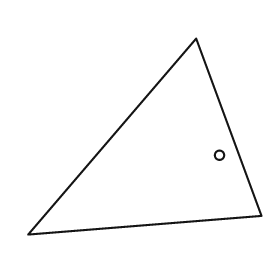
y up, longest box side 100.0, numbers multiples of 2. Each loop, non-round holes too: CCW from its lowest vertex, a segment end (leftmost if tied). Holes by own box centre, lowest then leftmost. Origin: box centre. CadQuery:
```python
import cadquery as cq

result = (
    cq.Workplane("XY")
    .moveTo(-50.0, -42.0)
    .lineTo(50.0, -34.0)
    .lineTo(22.0, 42.0)
    .close()
    .moveTo(32.0, -8.0)
    .circle(2.0)
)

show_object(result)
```